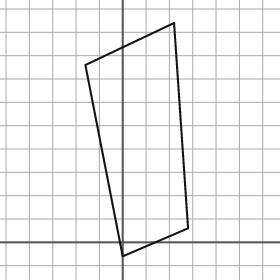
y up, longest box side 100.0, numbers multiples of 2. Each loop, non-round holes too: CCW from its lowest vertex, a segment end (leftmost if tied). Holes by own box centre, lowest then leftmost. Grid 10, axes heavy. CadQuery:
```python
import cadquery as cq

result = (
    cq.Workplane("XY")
    .moveTo(0.0, -6.0)
    .lineTo(28.0, 6.0)
    .lineTo(22.0, 94.0)
    .lineTo(-16.0, 76.0)
    .close()
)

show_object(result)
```